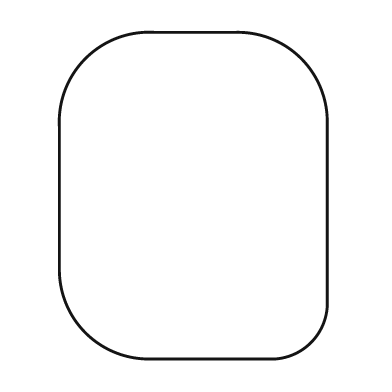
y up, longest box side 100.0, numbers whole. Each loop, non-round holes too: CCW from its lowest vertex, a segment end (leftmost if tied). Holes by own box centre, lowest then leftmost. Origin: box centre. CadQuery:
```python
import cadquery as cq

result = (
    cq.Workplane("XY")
    .moveTo(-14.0, -50.0)
    .lineTo(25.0, -50.0)
    .threePointArc((36.0, -45.0), (41.0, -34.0))
    .lineTo(41.0, 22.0)
    .threePointArc((33.0, 42.0), (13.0, 50.0))
    .lineTo(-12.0, 50.0)
    .threePointArc((-33.0, 42.0), (-41.0, 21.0))
    .lineTo(-41.0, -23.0)
    .threePointArc((-33.0, -42.0), (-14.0, -50.0))
    .close()
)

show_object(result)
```